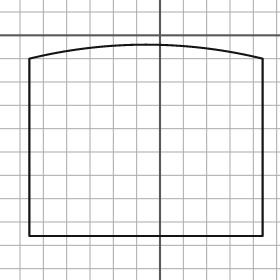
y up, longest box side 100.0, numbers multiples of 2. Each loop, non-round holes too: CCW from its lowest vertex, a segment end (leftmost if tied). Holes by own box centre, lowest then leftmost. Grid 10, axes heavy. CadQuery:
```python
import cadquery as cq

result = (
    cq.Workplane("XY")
    .moveTo(-56.0, -86.0)
    .lineTo(44.0, -86.0)
    .lineTo(44.0, -10.0)
    .threePointArc((-6.0, -4.0), (-56.0, -10.0))
    .close()
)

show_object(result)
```